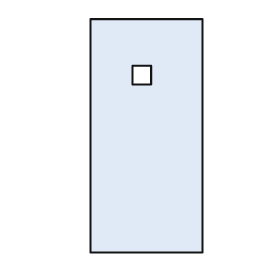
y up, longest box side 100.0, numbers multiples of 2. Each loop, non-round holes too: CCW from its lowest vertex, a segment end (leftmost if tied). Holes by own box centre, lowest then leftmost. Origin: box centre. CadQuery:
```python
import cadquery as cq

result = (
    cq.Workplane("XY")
    .moveTo(-24.0, -50.0)
    .lineTo(24.0, -50.0)
    .lineTo(24.0, 50.0)
    .lineTo(-24.0, 50.0)
    .close()
    .moveTo(-6.0, 22.0)
    .lineTo(2.0, 22.0)
    .lineTo(2.0, 30.0)
    .lineTo(-6.0, 30.0)
    .close()
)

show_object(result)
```